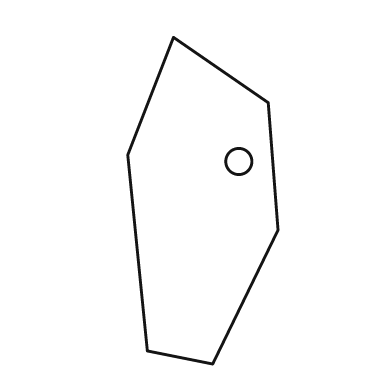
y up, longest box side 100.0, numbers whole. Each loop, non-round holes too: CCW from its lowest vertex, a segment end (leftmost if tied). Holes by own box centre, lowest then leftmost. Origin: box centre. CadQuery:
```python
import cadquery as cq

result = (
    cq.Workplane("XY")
    .moveTo(3.0, -50.0)
    .lineTo(23.0, -9.0)
    .lineTo(20.0, 30.0)
    .lineTo(-9.0, 50.0)
    .lineTo(-23.0, 14.0)
    .lineTo(-17.0, -46.0)
    .close()
    .moveTo(11.0, 12.0)
    .circle(4.0)
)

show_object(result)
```